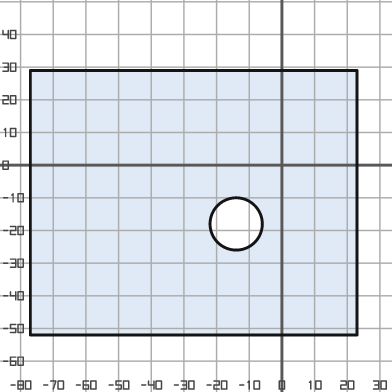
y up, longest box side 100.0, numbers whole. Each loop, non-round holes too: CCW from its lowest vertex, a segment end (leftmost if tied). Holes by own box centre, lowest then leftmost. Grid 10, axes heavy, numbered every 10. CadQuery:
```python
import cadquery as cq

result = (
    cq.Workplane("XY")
    .moveTo(-77.0, -52.0)
    .lineTo(23.0, -52.0)
    .lineTo(23.0, 29.0)
    .lineTo(-77.0, 29.0)
    .close()
    .moveTo(-14.0, -18.0)
    .circle(8.0)
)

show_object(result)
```